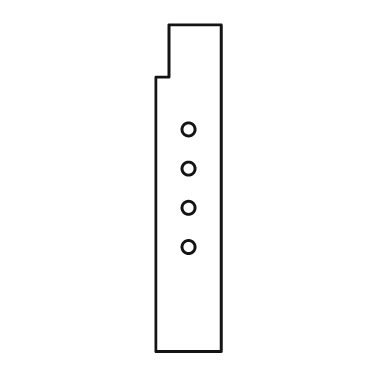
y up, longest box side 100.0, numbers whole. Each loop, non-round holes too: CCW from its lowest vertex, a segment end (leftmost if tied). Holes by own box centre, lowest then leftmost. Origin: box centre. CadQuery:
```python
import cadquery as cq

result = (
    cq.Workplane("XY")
    .moveTo(-10.0, -50.0)
    .lineTo(10.0, -50.0)
    .lineTo(10.0, 50.0)
    .lineTo(-6.0, 50.0)
    .lineTo(-6.0, 34.0)
    .lineTo(-10.0, 34.0)
    .close()
    .moveTo(0.0, -18.0)
    .circle(2.0)
    .moveTo(0.0, -6.0)
    .circle(2.0)
    .moveTo(0.0, 6.0)
    .circle(2.0)
    .moveTo(0.0, 18.0)
    .circle(2.0)
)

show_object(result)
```